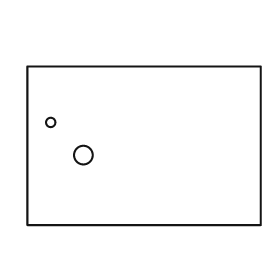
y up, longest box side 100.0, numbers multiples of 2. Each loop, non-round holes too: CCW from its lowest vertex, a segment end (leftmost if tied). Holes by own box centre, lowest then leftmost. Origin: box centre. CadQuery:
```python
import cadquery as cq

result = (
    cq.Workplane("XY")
    .moveTo(-50.0, -34.0)
    .lineTo(50.0, -34.0)
    .lineTo(50.0, 34.0)
    .lineTo(-50.0, 34.0)
    .close()
    .moveTo(-26.0, -4.0)
    .circle(4.0)
    .moveTo(-40.0, 10.0)
    .circle(2.0)
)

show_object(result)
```